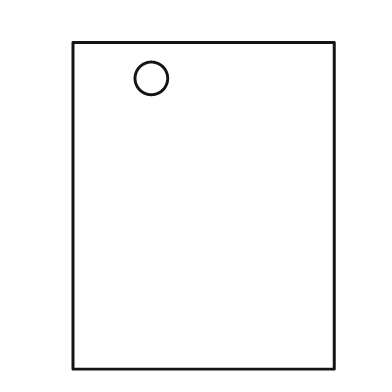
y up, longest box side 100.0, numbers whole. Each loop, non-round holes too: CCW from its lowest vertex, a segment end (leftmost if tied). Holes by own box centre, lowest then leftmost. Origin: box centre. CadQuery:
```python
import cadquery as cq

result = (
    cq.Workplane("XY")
    .moveTo(-40.0, -50.0)
    .lineTo(40.0, -50.0)
    .lineTo(40.0, 50.0)
    .lineTo(-40.0, 50.0)
    .close()
    .moveTo(-16.0, 39.0)
    .circle(5.0)
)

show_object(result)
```